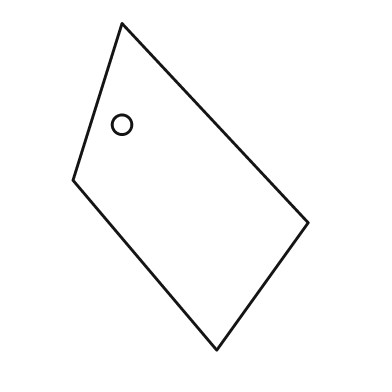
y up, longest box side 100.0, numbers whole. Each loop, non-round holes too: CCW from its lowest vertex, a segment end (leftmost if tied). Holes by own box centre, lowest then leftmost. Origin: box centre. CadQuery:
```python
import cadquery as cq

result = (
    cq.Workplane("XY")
    .moveTo(8.0, -50.0)
    .lineTo(36.0, -11.0)
    .lineTo(-21.0, 50.0)
    .lineTo(-36.0, 2.0)
    .close()
    .moveTo(-21.0, 19.0)
    .circle(3.0)
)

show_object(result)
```